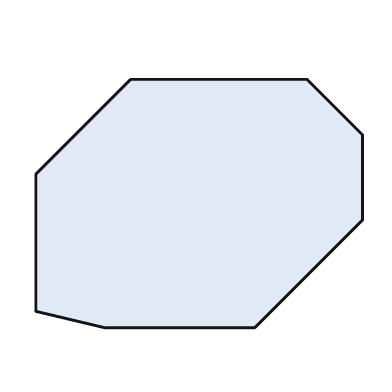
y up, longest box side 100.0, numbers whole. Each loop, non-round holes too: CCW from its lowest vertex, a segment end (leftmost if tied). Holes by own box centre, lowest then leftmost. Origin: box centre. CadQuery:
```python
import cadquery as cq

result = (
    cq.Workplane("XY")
    .moveTo(-29.0, -38.0)
    .lineTo(17.0, -38.0)
    .lineTo(50.0, -5.0)
    .lineTo(50.0, 21.0)
    .lineTo(33.0, 38.0)
    .lineTo(-21.0, 38.0)
    .lineTo(-50.0, 9.0)
    .lineTo(-50.0, -33.0)
    .close()
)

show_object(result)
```